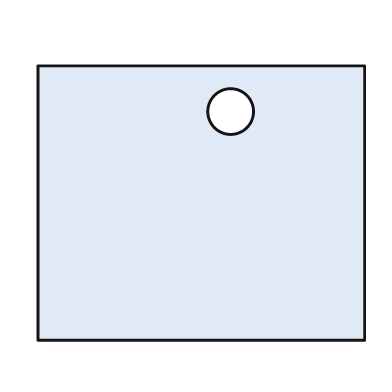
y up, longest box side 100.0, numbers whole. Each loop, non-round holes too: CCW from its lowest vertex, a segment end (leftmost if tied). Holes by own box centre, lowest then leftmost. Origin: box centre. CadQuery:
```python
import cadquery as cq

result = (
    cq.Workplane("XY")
    .moveTo(-50.0, -42.0)
    .lineTo(50.0, -42.0)
    .lineTo(50.0, 42.0)
    .lineTo(-50.0, 42.0)
    .close()
    .moveTo(9.0, 28.0)
    .circle(7.0)
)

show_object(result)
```